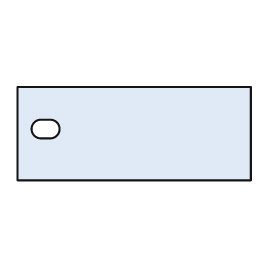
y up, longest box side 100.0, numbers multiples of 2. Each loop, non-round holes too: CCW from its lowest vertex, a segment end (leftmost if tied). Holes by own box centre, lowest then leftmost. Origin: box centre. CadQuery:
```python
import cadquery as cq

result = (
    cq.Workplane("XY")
    .moveTo(-50.0, -20.0)
    .lineTo(50.0, -20.0)
    .lineTo(50.0, 20.0)
    .lineTo(-50.0, 20.0)
    .close()
    .moveTo(-40.0, -2.0)
    .lineTo(-36.0, -2.0)
    .threePointArc((-32.0, 2.0), (-36.0, 6.0))
    .lineTo(-40.0, 6.0)
    .threePointArc((-44.0, 2.0), (-40.0, -2.0))
    .close()
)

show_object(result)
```